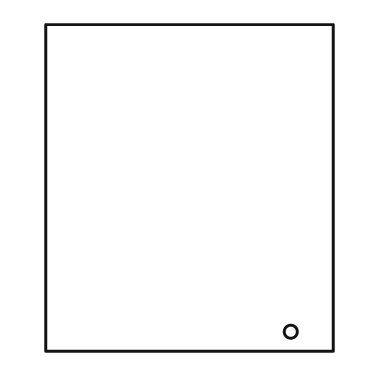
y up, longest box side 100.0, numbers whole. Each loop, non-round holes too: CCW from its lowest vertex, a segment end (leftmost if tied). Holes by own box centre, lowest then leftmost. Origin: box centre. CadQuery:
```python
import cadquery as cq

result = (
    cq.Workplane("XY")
    .moveTo(-44.0, -50.0)
    .lineTo(44.0, -50.0)
    .lineTo(44.0, 50.0)
    .lineTo(-44.0, 50.0)
    .close()
    .moveTo(31.0, -44.0)
    .circle(2.0)
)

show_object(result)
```